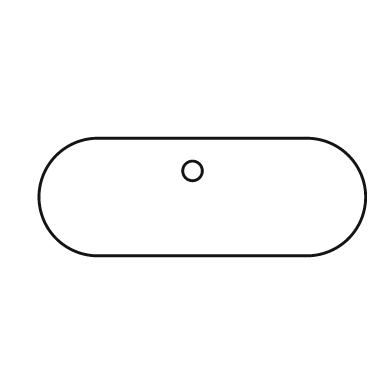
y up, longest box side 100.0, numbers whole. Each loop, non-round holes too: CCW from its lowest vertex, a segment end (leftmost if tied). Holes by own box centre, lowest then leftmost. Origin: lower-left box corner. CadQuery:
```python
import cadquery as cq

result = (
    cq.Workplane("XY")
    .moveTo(18.0, 0.0)
    .lineTo(82.0, 0.0)
    .threePointArc((100.0, 18.0), (82.0, 36.0))
    .lineTo(18.0, 36.0)
    .threePointArc((0.0, 18.0), (18.0, 0.0))
    .close()
    .moveTo(47.0, 26.0)
    .circle(3.0)
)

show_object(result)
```